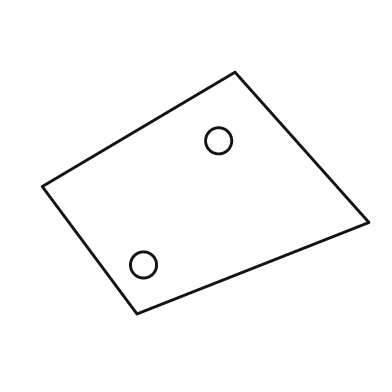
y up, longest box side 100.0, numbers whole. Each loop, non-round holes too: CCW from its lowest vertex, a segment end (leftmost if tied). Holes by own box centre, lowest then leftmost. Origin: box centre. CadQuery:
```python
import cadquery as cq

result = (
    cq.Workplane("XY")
    .moveTo(-21.0, -37.0)
    .lineTo(50.0, -9.0)
    .lineTo(9.0, 37.0)
    .lineTo(-50.0, 2.0)
    .close()
    .moveTo(-19.0, -22.0)
    .circle(4.0)
    .moveTo(4.0, 16.0)
    .circle(4.0)
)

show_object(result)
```